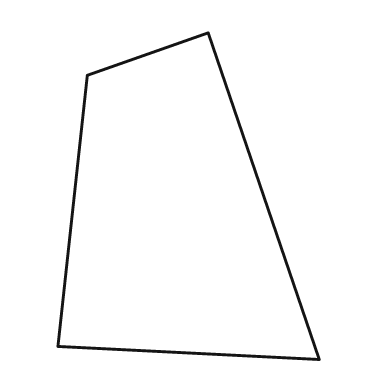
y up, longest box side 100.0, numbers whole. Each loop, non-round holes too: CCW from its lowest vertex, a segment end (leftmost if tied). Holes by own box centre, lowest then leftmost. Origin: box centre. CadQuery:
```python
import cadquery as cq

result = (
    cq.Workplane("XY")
    .moveTo(40.0, -50.0)
    .lineTo(6.0, 50.0)
    .lineTo(-31.0, 37.0)
    .lineTo(-40.0, -46.0)
    .close()
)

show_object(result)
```